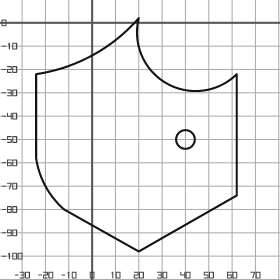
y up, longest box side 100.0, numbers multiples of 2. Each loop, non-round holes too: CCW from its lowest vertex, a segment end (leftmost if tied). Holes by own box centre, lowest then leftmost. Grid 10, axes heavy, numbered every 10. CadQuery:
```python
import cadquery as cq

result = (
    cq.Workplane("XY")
    .moveTo(20.0, -98.0)
    .lineTo(62.0, -74.0)
    .lineTo(62.0, -22.0)
    .threePointArc((32.0, -26.0), (20.0, 2.0))
    .threePointArc((0.0, -14.0), (-24.0, -22.0))
    .lineTo(-24.0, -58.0)
    .threePointArc((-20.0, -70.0), (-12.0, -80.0))
    .close()
    .moveTo(40.0, -50.0)
    .circle(4.0)
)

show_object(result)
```